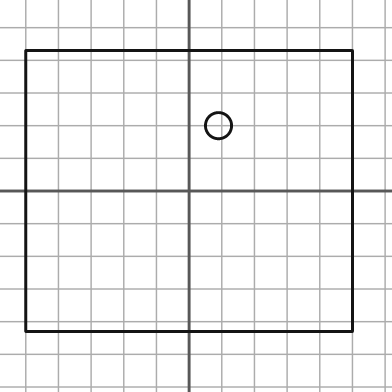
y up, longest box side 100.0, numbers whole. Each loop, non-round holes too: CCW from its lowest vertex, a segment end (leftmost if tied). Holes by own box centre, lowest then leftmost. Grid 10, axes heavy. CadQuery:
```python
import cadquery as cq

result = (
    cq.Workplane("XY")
    .moveTo(-50.0, -43.0)
    .lineTo(50.0, -43.0)
    .lineTo(50.0, 43.0)
    .lineTo(-50.0, 43.0)
    .close()
    .moveTo(9.0, 20.0)
    .circle(4.0)
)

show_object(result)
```